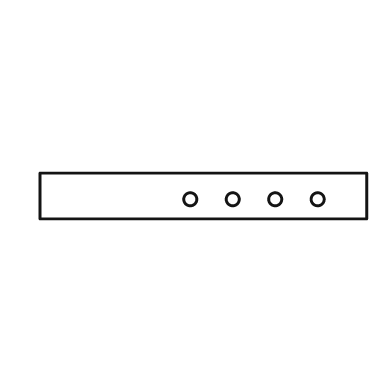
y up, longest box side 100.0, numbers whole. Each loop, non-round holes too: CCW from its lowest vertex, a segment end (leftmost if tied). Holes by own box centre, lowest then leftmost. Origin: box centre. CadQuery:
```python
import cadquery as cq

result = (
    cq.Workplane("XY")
    .moveTo(-50.0, -7.0)
    .lineTo(50.0, -7.0)
    .lineTo(50.0, 7.0)
    .lineTo(-50.0, 7.0)
    .close()
    .moveTo(-4.0, -1.0)
    .circle(2.0)
    .moveTo(9.0, -1.0)
    .circle(2.0)
    .moveTo(22.0, -1.0)
    .circle(2.0)
    .moveTo(35.0, -1.0)
    .circle(2.0)
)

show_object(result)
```